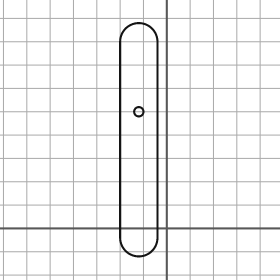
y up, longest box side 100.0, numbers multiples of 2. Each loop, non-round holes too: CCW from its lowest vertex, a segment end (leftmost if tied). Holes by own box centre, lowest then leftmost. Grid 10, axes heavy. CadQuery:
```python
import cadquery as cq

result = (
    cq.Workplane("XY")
    .moveTo(-20.0, -4.0)
    .threePointArc((-12.0, -12.0), (-4.0, -4.0))
    .lineTo(-4.0, 80.0)
    .threePointArc((-12.0, 88.0), (-20.0, 80.0))
    .close()
    .moveTo(-12.0, 50.0)
    .circle(2.0)
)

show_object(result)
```